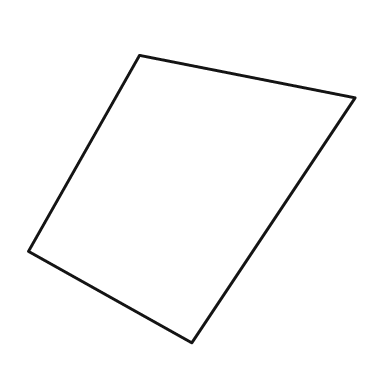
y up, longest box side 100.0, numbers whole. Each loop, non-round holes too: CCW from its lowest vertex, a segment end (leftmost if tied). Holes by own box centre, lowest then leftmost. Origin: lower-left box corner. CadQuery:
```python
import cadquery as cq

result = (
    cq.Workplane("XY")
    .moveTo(50.0, 0.0)
    .lineTo(100.0, 75.0)
    .lineTo(34.0, 88.0)
    .lineTo(0.0, 28.0)
    .close()
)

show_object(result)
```